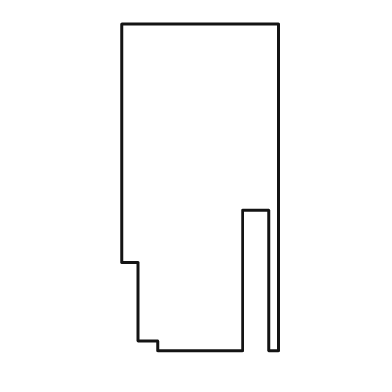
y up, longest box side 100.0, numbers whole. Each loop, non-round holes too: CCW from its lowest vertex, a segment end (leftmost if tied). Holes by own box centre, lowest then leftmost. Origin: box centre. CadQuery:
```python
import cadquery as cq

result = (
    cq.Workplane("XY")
    .moveTo(-13.0, -50.0)
    .lineTo(13.0, -50.0)
    .lineTo(13.0, -7.0)
    .lineTo(21.0, -7.0)
    .lineTo(21.0, -50.0)
    .lineTo(24.0, -50.0)
    .lineTo(24.0, 50.0)
    .lineTo(-24.0, 50.0)
    .lineTo(-24.0, -23.0)
    .lineTo(-19.0, -23.0)
    .lineTo(-19.0, -47.0)
    .lineTo(-13.0, -47.0)
    .close()
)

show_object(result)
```